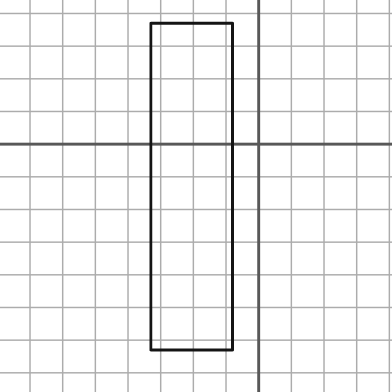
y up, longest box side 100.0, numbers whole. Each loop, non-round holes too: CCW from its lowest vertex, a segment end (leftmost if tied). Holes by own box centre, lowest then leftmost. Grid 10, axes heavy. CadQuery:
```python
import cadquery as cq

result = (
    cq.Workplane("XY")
    .moveTo(-33.0, -63.0)
    .lineTo(-8.0, -63.0)
    .lineTo(-8.0, 37.0)
    .lineTo(-33.0, 37.0)
    .close()
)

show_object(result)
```